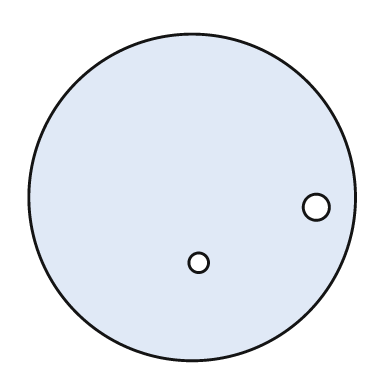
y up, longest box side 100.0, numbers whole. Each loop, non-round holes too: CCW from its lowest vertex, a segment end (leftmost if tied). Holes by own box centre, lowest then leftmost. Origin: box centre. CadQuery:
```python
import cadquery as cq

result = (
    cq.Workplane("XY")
    .moveTo(0.0, 0.0)
    .circle(50.0)
    .moveTo(2.0, -20.0)
    .circle(3.0)
    .moveTo(38.0, -3.0)
    .circle(4.0)
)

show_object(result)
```